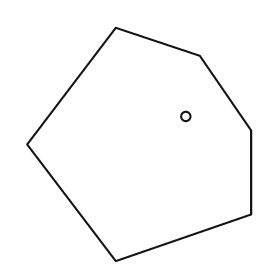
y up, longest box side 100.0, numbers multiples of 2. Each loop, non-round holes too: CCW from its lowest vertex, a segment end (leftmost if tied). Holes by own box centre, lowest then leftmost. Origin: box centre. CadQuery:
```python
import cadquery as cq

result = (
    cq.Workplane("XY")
    .moveTo(-10.0, -50.0)
    .lineTo(48.0, -30.0)
    .lineTo(48.0, 6.0)
    .lineTo(26.0, 38.0)
    .lineTo(-10.0, 50.0)
    .lineTo(-48.0, 0.0)
    .close()
    .moveTo(20.0, 12.0)
    .circle(2.0)
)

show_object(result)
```